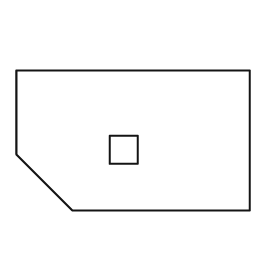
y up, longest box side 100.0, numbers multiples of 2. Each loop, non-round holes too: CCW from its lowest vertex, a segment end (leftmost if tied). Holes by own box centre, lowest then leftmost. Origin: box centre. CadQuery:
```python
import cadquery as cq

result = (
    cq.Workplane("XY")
    .moveTo(-26.0, -30.0)
    .lineTo(50.0, -30.0)
    .lineTo(50.0, 30.0)
    .lineTo(-50.0, 30.0)
    .lineTo(-50.0, -6.0)
    .close()
    .moveTo(-10.0, -10.0)
    .lineTo(2.0, -10.0)
    .lineTo(2.0, 2.0)
    .lineTo(-10.0, 2.0)
    .close()
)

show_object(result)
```